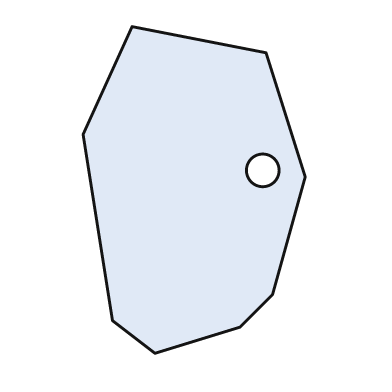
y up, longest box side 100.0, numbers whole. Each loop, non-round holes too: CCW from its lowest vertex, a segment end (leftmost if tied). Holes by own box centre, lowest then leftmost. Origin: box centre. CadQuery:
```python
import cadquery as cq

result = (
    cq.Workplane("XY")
    .moveTo(-12.0, -50.0)
    .lineTo(14.0, -42.0)
    .lineTo(24.0, -32.0)
    .lineTo(34.0, 4.0)
    .lineTo(22.0, 42.0)
    .lineTo(-19.0, 50.0)
    .lineTo(-34.0, 17.0)
    .lineTo(-25.0, -40.0)
    .close()
    .moveTo(21.0, 6.0)
    .circle(5.0)
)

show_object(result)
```